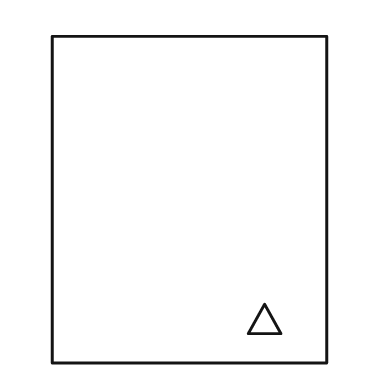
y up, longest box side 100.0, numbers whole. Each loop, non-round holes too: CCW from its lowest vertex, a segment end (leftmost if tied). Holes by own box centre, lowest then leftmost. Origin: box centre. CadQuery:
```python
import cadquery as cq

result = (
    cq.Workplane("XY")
    .moveTo(-42.0, -50.0)
    .lineTo(42.0, -50.0)
    .lineTo(42.0, 50.0)
    .lineTo(-42.0, 50.0)
    .close()
    .moveTo(18.0, -41.0)
    .lineTo(28.0, -41.0)
    .lineTo(23.0, -32.0)
    .close()
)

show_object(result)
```